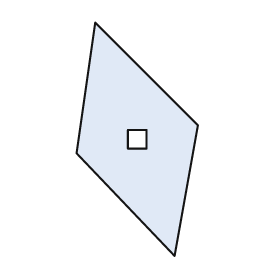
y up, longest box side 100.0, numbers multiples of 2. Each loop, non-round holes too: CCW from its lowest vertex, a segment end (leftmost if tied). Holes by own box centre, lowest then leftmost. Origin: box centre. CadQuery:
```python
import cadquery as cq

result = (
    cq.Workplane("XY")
    .moveTo(16.0, -50.0)
    .lineTo(26.0, 6.0)
    .lineTo(-18.0, 50.0)
    .lineTo(-26.0, -6.0)
    .close()
    .moveTo(-4.0, -4.0)
    .lineTo(4.0, -4.0)
    .lineTo(4.0, 4.0)
    .lineTo(-4.0, 4.0)
    .close()
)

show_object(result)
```